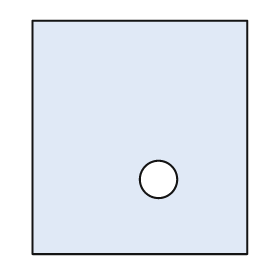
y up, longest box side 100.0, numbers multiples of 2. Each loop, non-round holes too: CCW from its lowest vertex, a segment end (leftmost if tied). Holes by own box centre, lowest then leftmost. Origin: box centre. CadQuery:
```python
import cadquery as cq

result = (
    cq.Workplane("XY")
    .moveTo(-46.0, -50.0)
    .lineTo(46.0, -50.0)
    .lineTo(46.0, 50.0)
    .lineTo(-46.0, 50.0)
    .close()
    .moveTo(8.0, -18.0)
    .circle(8.0)
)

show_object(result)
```